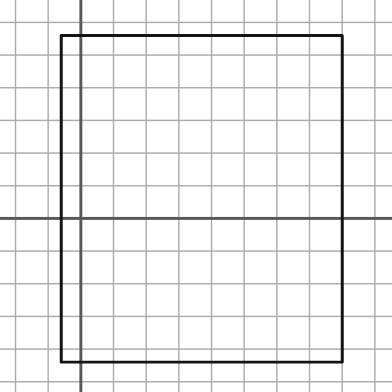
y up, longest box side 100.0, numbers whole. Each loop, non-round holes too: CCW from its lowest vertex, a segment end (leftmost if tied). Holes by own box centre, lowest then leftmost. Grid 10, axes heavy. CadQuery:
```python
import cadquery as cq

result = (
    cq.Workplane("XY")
    .moveTo(-6.0, -44.0)
    .lineTo(80.0, -44.0)
    .lineTo(80.0, 56.0)
    .lineTo(-6.0, 56.0)
    .close()
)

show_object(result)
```